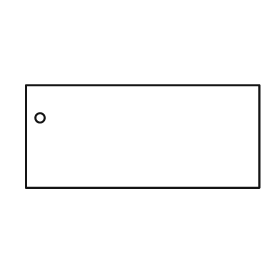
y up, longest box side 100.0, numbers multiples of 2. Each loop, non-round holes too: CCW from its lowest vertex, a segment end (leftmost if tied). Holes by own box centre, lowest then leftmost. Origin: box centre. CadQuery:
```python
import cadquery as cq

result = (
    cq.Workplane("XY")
    .moveTo(-50.0, -22.0)
    .lineTo(50.0, -22.0)
    .lineTo(50.0, 22.0)
    .lineTo(-50.0, 22.0)
    .close()
    .moveTo(-44.0, 8.0)
    .circle(2.0)
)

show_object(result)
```